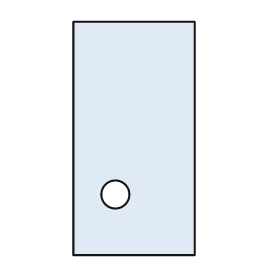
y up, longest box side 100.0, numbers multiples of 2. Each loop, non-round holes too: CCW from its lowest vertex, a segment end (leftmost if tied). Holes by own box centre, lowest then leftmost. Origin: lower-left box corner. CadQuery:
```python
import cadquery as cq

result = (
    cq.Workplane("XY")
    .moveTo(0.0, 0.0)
    .lineTo(52.0, 0.0)
    .lineTo(52.0, 100.0)
    .lineTo(0.0, 100.0)
    .close()
    .moveTo(18.0, 26.0)
    .circle(6.0)
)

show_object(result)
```